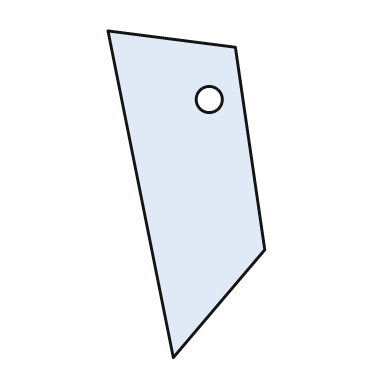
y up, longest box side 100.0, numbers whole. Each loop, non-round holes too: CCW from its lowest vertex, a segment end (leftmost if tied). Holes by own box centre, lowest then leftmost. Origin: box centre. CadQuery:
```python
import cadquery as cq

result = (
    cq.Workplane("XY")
    .moveTo(-4.0, -50.0)
    .lineTo(24.0, -17.0)
    .lineTo(15.0, 45.0)
    .lineTo(-24.0, 50.0)
    .close()
    .moveTo(7.0, 29.0)
    .circle(4.0)
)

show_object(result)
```